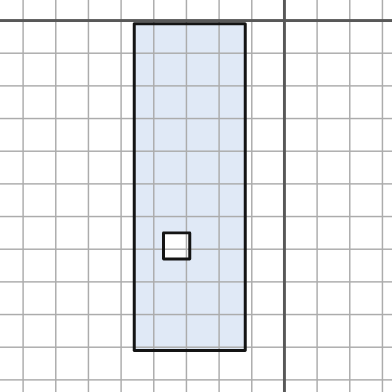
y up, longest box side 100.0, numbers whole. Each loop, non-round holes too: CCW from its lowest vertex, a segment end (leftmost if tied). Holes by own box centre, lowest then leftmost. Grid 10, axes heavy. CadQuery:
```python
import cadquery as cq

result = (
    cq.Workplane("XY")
    .moveTo(-46.0, -101.0)
    .lineTo(-12.0, -101.0)
    .lineTo(-12.0, -1.0)
    .lineTo(-46.0, -1.0)
    .close()
    .moveTo(-37.0, -73.0)
    .lineTo(-29.0, -73.0)
    .lineTo(-29.0, -65.0)
    .lineTo(-37.0, -65.0)
    .close()
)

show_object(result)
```